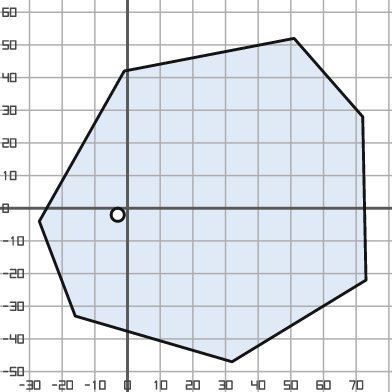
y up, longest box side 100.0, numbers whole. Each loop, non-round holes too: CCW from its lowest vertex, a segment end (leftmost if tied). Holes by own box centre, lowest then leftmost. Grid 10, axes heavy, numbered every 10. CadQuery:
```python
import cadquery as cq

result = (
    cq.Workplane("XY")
    .moveTo(32.0, -47.0)
    .lineTo(73.0, -22.0)
    .lineTo(72.0, 28.0)
    .lineTo(51.0, 52.0)
    .lineTo(-1.0, 42.0)
    .lineTo(-27.0, -4.0)
    .lineTo(-16.0, -33.0)
    .close()
    .moveTo(-3.0, -2.0)
    .circle(2.0)
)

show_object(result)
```